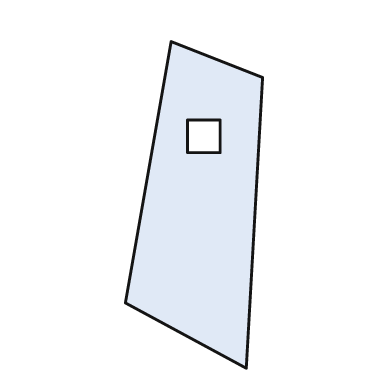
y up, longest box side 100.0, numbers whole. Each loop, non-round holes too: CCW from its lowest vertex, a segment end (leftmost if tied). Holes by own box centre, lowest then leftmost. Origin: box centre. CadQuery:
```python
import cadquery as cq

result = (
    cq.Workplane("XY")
    .moveTo(16.0, -50.0)
    .lineTo(21.0, 39.0)
    .lineTo(-7.0, 50.0)
    .lineTo(-21.0, -30.0)
    .close()
    .moveTo(-2.0, 16.0)
    .lineTo(8.0, 16.0)
    .lineTo(8.0, 26.0)
    .lineTo(-2.0, 26.0)
    .close()
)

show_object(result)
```